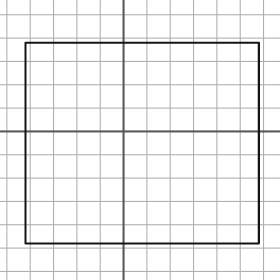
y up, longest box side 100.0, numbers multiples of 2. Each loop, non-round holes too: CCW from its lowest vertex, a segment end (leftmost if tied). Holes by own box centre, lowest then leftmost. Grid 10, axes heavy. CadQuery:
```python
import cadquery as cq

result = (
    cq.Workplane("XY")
    .moveTo(-42.0, -48.0)
    .lineTo(58.0, -48.0)
    .lineTo(58.0, 38.0)
    .lineTo(-42.0, 38.0)
    .close()
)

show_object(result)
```